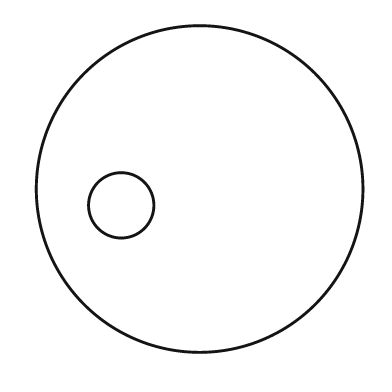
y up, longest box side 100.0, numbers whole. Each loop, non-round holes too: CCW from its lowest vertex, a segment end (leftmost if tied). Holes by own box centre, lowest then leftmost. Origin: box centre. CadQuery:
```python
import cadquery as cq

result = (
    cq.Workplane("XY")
    .moveTo(0.0, 0.0)
    .circle(50.0)
    .moveTo(-24.0, -5.0)
    .circle(10.0)
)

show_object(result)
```